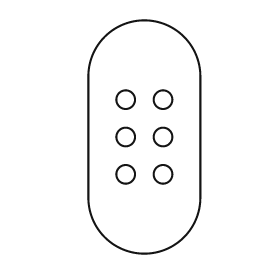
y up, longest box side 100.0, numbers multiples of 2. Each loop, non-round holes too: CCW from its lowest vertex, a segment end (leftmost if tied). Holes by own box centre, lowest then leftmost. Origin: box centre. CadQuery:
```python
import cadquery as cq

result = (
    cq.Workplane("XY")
    .moveTo(-24.0, -26.0)
    .threePointArc((0.0, -50.0), (24.0, -26.0))
    .lineTo(24.0, 26.0)
    .threePointArc((0.0, 50.0), (-24.0, 26.0))
    .close()
    .moveTo(-8.0, -16.0)
    .circle(4.0)
    .moveTo(8.0, -16.0)
    .circle(4.0)
    .moveTo(-8.0, 0.0)
    .circle(4.0)
    .moveTo(8.0, 0.0)
    .circle(4.0)
    .moveTo(-8.0, 16.0)
    .circle(4.0)
    .moveTo(8.0, 16.0)
    .circle(4.0)
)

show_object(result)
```